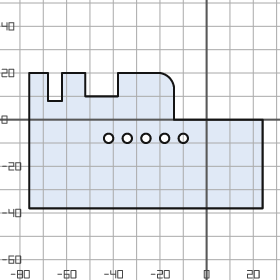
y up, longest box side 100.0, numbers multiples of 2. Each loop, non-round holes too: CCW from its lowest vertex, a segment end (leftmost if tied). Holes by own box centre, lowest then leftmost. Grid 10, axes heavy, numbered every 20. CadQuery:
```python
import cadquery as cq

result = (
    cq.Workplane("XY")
    .moveTo(-76.0, -38.0)
    .lineTo(24.0, -38.0)
    .lineTo(24.0, 0.0)
    .lineTo(-14.0, 0.0)
    .lineTo(-14.0, 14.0)
    .threePointArc((-16.0, 18.0), (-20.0, 20.0))
    .lineTo(-38.0, 20.0)
    .lineTo(-38.0, 10.0)
    .lineTo(-52.0, 10.0)
    .lineTo(-52.0, 20.0)
    .lineTo(-62.0, 20.0)
    .lineTo(-62.0, 8.0)
    .lineTo(-68.0, 8.0)
    .lineTo(-68.0, 20.0)
    .lineTo(-76.0, 20.0)
    .close()
    .moveTo(-42.0, -8.0)
    .circle(2.0)
    .moveTo(-34.0, -8.0)
    .circle(2.0)
    .moveTo(-26.0, -8.0)
    .circle(2.0)
    .moveTo(-18.0, -8.0)
    .circle(2.0)
    .moveTo(-10.0, -8.0)
    .circle(2.0)
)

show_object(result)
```